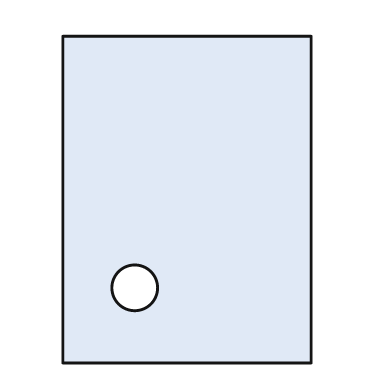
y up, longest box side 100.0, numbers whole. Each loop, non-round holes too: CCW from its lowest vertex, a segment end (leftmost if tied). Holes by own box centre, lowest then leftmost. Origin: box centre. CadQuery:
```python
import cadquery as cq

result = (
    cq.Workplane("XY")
    .moveTo(-38.0, -50.0)
    .lineTo(38.0, -50.0)
    .lineTo(38.0, 50.0)
    .lineTo(-38.0, 50.0)
    .close()
    .moveTo(-16.0, -27.0)
    .circle(7.0)
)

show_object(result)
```